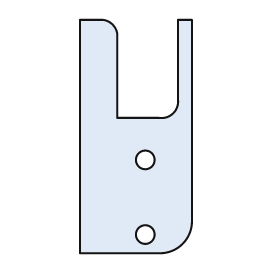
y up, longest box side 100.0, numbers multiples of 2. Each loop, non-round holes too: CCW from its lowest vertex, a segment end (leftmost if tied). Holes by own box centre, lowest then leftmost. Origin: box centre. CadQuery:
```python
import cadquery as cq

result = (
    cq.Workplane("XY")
    .moveTo(-24.0, -50.0)
    .lineTo(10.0, -50.0)
    .threePointArc((20.0, -46.0), (24.0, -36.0))
    .lineTo(24.0, 50.0)
    .lineTo(18.0, 50.0)
    .lineTo(18.0, 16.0)
    .threePointArc((16.0, 10.0), (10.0, 8.0))
    .lineTo(-8.0, 8.0)
    .lineTo(-8.0, 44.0)
    .threePointArc((-10.0, 48.0), (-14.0, 50.0))
    .lineTo(-24.0, 50.0)
    .close()
    .moveTo(4.0, -42.0)
    .circle(4.0)
    .moveTo(4.0, -10.0)
    .circle(4.0)
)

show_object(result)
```